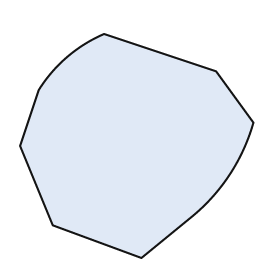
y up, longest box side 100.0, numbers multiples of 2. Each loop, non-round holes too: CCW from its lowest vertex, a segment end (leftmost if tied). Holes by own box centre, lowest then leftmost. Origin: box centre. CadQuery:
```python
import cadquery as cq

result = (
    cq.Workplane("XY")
    .moveTo(2.0, -48.0)
    .lineTo(24.0, -30.0)
    .threePointArc((40.0, -12.0), (50.0, 10.0))
    .lineTo(34.0, 32.0)
    .lineTo(-14.0, 48.0)
    .threePointArc((-30.0, 38.0), (-42.0, 24.0))
    .lineTo(-50.0, 0.0)
    .lineTo(-36.0, -34.0)
    .close()
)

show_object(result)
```